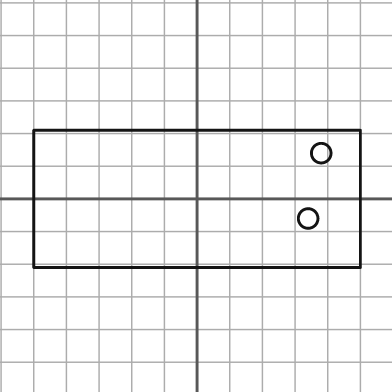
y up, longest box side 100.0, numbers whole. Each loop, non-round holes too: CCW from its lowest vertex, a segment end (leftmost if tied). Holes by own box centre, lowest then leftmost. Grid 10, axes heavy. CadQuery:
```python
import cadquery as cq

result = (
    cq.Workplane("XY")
    .moveTo(-50.0, -21.0)
    .lineTo(50.0, -21.0)
    .lineTo(50.0, 21.0)
    .lineTo(-50.0, 21.0)
    .close()
    .moveTo(34.0, -6.0)
    .circle(3.0)
    .moveTo(38.0, 14.0)
    .circle(3.0)
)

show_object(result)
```